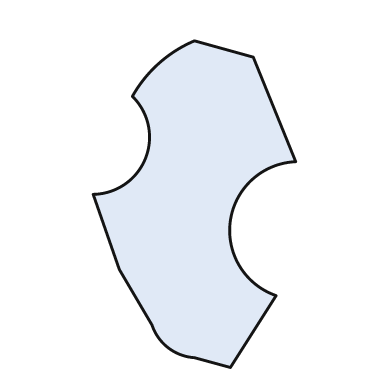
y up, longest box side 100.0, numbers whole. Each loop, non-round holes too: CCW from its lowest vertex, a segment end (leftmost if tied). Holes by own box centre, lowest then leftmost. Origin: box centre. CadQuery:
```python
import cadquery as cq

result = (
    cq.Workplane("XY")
    .moveTo(11.0, -50.0)
    .lineTo(25.0, -28.0)
    .threePointArc((11.0, -5.0), (31.0, 13.0))
    .lineTo(18.0, 45.0)
    .lineTo(0.0, 50.0)
    .threePointArc((-11.0, 43.0), (-19.0, 33.0))
    .threePointArc((-15.0, 14.0), (-31.0, 3.0))
    .lineTo(-23.0, -20.0)
    .lineTo(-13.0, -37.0)
    .threePointArc((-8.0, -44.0), (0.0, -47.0))
    .close()
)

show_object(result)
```